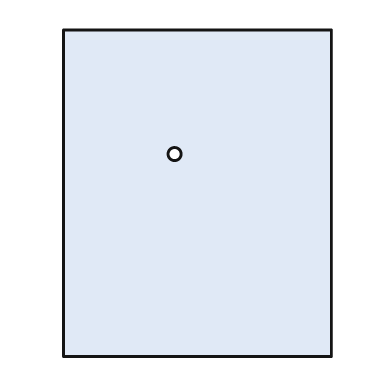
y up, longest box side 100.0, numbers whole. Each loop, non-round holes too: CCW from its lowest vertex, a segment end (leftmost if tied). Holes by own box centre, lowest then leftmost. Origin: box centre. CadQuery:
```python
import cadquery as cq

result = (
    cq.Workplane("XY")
    .moveTo(-41.0, -50.0)
    .lineTo(41.0, -50.0)
    .lineTo(41.0, 50.0)
    .lineTo(-41.0, 50.0)
    .close()
    .moveTo(-7.0, 12.0)
    .circle(2.0)
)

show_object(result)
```